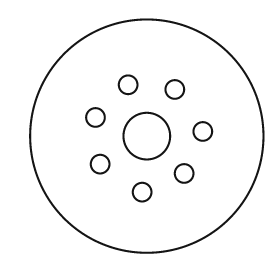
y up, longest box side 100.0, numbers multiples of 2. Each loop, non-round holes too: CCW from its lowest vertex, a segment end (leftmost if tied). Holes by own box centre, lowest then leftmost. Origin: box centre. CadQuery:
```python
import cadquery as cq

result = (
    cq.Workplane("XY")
    .moveTo(0.0, 0.0)
    .circle(50.0)
    .moveTo(-2.0, -24.0)
    .circle(4.0)
    .moveTo(16.0, -16.0)
    .circle(4.0)
    .moveTo(-20.0, -12.0)
    .circle(4.0)
    .moveTo(0.0, 0.0)
    .circle(10.0)
    .moveTo(24.0, 2.0)
    .circle(4.0)
    .moveTo(-22.0, 8.0)
    .circle(4.0)
    .moveTo(12.0, 20.0)
    .circle(4.0)
    .moveTo(-8.0, 22.0)
    .circle(4.0)
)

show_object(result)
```